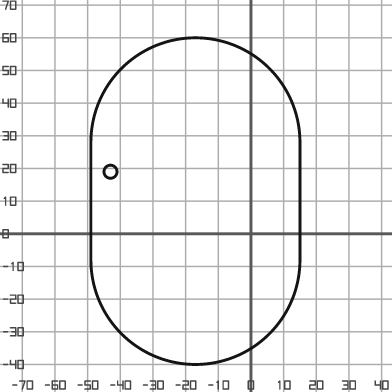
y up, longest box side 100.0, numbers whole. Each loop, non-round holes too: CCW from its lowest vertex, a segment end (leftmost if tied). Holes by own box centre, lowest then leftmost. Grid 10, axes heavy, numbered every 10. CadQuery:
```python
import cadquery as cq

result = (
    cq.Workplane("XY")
    .moveTo(-49.0, -8.0)
    .threePointArc((-17.0, -40.0), (15.0, -8.0))
    .lineTo(15.0, 28.0)
    .threePointArc((-17.0, 60.0), (-49.0, 28.0))
    .close()
    .moveTo(-43.0, 19.0)
    .circle(2.0)
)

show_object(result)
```